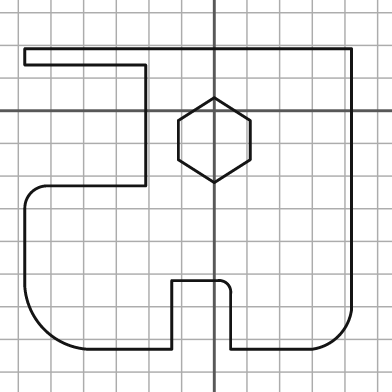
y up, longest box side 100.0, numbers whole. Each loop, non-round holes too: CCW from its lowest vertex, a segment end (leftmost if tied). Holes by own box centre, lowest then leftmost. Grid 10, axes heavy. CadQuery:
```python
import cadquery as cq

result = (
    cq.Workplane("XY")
    .moveTo(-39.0, -73.0)
    .lineTo(-13.0, -73.0)
    .lineTo(-13.0, -52.0)
    .lineTo(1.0, -52.0)
    .threePointArc((4.0, -53.0), (5.0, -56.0))
    .lineTo(5.0, -73.0)
    .lineTo(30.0, -73.0)
    .threePointArc((38.0, -69.0), (42.0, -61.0))
    .lineTo(42.0, 19.0)
    .lineTo(-58.0, 19.0)
    .lineTo(-58.0, 14.0)
    .lineTo(-21.0, 14.0)
    .lineTo(-21.0, -23.0)
    .lineTo(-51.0, -23.0)
    .threePointArc((-56.0, -25.0), (-58.0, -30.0))
    .lineTo(-58.0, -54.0)
    .threePointArc((-52.0, -67.0), (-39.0, -73.0))
    .close()
    .moveTo(0.0, -22.0)
    .lineTo(11.0, -15.0)
    .lineTo(11.0, -3.0)
    .lineTo(0.0, 4.0)
    .lineTo(-11.0, -3.0)
    .lineTo(-11.0, -15.0)
    .close()
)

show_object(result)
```